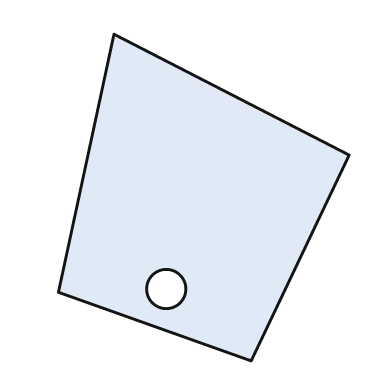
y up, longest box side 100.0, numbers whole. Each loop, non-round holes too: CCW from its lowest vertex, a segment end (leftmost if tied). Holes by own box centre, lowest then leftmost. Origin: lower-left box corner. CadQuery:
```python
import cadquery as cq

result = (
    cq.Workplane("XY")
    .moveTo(59.0, 0.0)
    .lineTo(89.0, 63.0)
    .lineTo(17.0, 100.0)
    .lineTo(0.0, 21.0)
    .close()
    .moveTo(33.0, 22.0)
    .circle(6.0)
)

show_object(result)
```